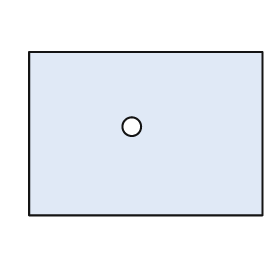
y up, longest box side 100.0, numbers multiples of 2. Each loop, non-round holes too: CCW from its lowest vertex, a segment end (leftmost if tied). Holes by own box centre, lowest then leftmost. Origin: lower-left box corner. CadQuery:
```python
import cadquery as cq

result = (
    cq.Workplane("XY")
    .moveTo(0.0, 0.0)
    .lineTo(100.0, 0.0)
    .lineTo(100.0, 70.0)
    .lineTo(0.0, 70.0)
    .close()
    .moveTo(44.0, 38.0)
    .circle(4.0)
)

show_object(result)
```